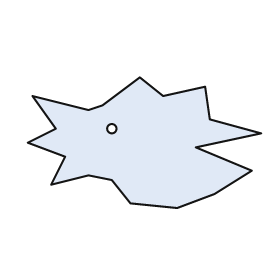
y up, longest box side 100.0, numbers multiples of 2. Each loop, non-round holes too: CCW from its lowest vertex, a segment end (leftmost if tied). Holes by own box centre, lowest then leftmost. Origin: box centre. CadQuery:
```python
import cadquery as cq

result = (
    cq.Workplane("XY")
    .moveTo(14.0, -28.0)
    .lineTo(30.0, -22.0)
    .lineTo(46.0, -12.0)
    .lineTo(22.0, -2.0)
    .lineTo(50.0, 4.0)
    .lineTo(28.0, 10.0)
    .lineTo(26.0, 24.0)
    .lineTo(8.0, 20.0)
    .lineTo(-2.0, 28.0)
    .lineTo(-18.0, 16.0)
    .lineTo(-24.0, 14.0)
    .lineTo(-48.0, 20.0)
    .lineTo(-38.0, 6.0)
    .lineTo(-50.0, 0.0)
    .lineTo(-34.0, -6.0)
    .lineTo(-40.0, -18.0)
    .lineTo(-24.0, -14.0)
    .lineTo(-14.0, -16.0)
    .lineTo(-6.0, -26.0)
    .close()
    .moveTo(-14.0, 6.0)
    .circle(2.0)
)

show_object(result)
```